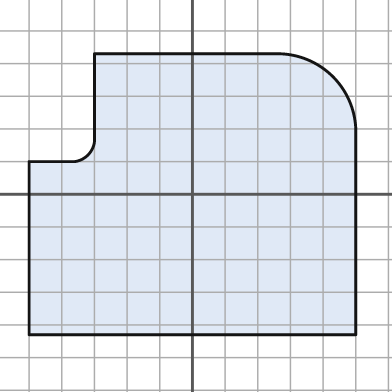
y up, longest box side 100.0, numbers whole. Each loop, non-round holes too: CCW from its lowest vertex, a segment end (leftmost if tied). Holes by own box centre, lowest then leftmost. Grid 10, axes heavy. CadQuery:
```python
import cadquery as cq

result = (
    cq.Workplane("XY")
    .moveTo(-50.0, -43.0)
    .lineTo(50.0, -43.0)
    .lineTo(50.0, 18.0)
    .threePointArc((43.0, 36.0), (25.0, 43.0))
    .lineTo(-30.0, 43.0)
    .lineTo(-30.0, 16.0)
    .threePointArc((-32.0, 12.0), (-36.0, 10.0))
    .lineTo(-50.0, 10.0)
    .close()
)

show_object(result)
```